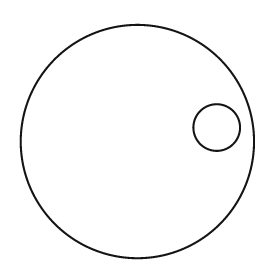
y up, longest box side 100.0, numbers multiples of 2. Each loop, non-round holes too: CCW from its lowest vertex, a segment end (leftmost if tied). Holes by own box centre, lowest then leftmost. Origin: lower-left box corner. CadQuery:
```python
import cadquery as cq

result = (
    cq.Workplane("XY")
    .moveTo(50.0, 50.0)
    .circle(50.0)
    .moveTo(84.0, 56.0)
    .circle(10.0)
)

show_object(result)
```